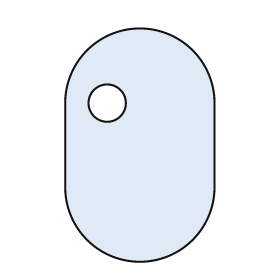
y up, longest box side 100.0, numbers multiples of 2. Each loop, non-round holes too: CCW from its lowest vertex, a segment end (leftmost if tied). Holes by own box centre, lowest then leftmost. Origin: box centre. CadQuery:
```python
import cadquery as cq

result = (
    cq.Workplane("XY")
    .moveTo(-32.0, -18.0)
    .threePointArc((0.0, -50.0), (32.0, -18.0))
    .lineTo(32.0, 18.0)
    .threePointArc((0.0, 50.0), (-32.0, 18.0))
    .close()
    .moveTo(-14.0, 18.0)
    .circle(8.0)
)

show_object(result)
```